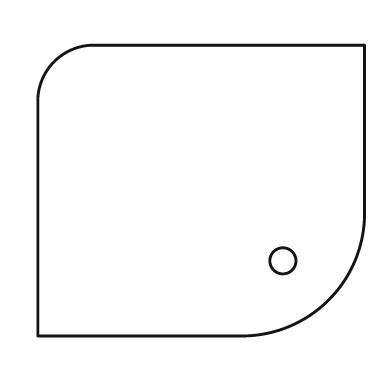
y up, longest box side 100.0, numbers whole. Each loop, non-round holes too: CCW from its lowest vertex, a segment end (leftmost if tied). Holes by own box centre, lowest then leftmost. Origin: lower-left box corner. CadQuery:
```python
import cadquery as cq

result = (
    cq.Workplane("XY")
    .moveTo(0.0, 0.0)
    .lineTo(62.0, 0.0)
    .threePointArc((89.0, 11.0), (100.0, 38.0))
    .lineTo(100.0, 89.0)
    .lineTo(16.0, 89.0)
    .threePointArc((5.0, 84.0), (0.0, 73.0))
    .close()
    .moveTo(75.0, 23.0)
    .circle(4.0)
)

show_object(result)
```